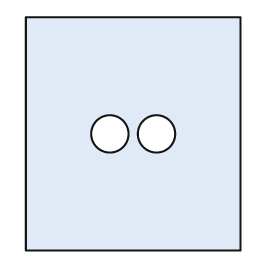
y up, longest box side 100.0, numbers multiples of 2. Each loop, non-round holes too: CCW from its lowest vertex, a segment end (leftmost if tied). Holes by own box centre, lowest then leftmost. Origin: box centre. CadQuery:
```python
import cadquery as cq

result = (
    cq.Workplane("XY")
    .moveTo(-46.0, -50.0)
    .lineTo(46.0, -50.0)
    .lineTo(46.0, 50.0)
    .lineTo(-46.0, 50.0)
    .close()
    .moveTo(-10.0, 0.0)
    .circle(8.0)
    .moveTo(10.0, 0.0)
    .circle(8.0)
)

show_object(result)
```